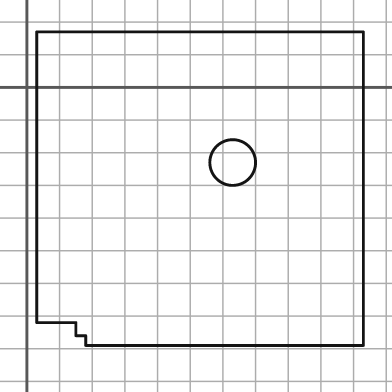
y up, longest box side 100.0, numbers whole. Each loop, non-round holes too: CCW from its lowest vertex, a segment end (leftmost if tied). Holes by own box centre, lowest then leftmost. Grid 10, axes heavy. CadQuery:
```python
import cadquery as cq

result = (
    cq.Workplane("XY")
    .moveTo(18.0, -79.0)
    .lineTo(103.0, -79.0)
    .lineTo(103.0, 17.0)
    .lineTo(3.0, 17.0)
    .lineTo(3.0, -72.0)
    .lineTo(15.0, -72.0)
    .lineTo(15.0, -76.0)
    .lineTo(18.0, -76.0)
    .close()
    .moveTo(63.0, -23.0)
    .circle(7.0)
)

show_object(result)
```